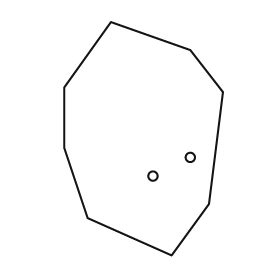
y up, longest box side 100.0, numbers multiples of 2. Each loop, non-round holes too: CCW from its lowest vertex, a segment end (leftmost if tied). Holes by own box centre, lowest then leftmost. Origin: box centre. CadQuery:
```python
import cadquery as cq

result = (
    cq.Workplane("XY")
    .moveTo(12.0, -50.0)
    .lineTo(28.0, -28.0)
    .lineTo(34.0, 20.0)
    .lineTo(20.0, 38.0)
    .lineTo(-14.0, 50.0)
    .lineTo(-34.0, 22.0)
    .lineTo(-34.0, -4.0)
    .lineTo(-24.0, -34.0)
    .close()
    .moveTo(4.0, -16.0)
    .circle(2.0)
    .moveTo(20.0, -8.0)
    .circle(2.0)
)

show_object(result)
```